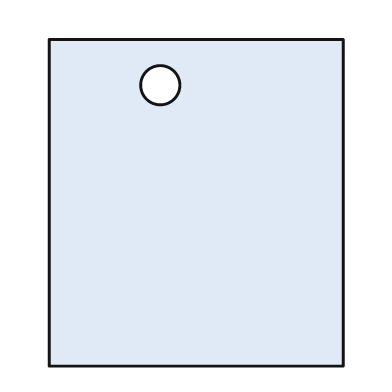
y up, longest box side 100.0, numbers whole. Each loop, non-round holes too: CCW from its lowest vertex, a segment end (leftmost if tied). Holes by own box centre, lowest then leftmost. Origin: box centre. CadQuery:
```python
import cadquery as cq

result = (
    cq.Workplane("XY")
    .moveTo(-45.0, -50.0)
    .lineTo(45.0, -50.0)
    .lineTo(45.0, 50.0)
    .lineTo(-45.0, 50.0)
    .close()
    .moveTo(-11.0, 36.0)
    .circle(6.0)
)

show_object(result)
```